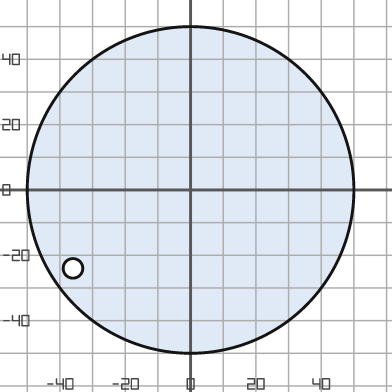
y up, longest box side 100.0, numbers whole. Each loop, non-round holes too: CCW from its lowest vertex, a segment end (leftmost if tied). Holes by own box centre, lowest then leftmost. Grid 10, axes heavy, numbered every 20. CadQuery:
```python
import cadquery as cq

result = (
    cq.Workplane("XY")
    .moveTo(0.0, 0.0)
    .circle(50.0)
    .moveTo(-36.0, -24.0)
    .circle(3.0)
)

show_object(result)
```